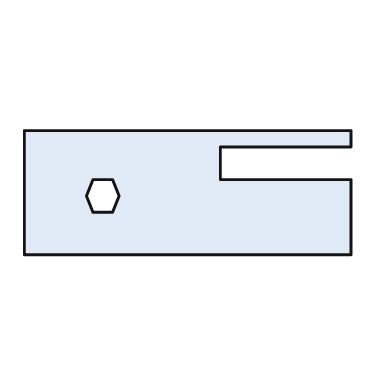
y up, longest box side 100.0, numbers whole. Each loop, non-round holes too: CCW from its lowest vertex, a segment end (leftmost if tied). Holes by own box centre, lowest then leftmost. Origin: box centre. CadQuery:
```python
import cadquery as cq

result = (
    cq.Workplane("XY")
    .moveTo(-50.0, -19.0)
    .lineTo(50.0, -19.0)
    .lineTo(50.0, 4.0)
    .lineTo(10.0, 4.0)
    .lineTo(10.0, 14.0)
    .lineTo(50.0, 14.0)
    .lineTo(50.0, 19.0)
    .lineTo(-50.0, 19.0)
    .close()
    .moveTo(-29.0, -6.0)
    .lineTo(-23.0, -6.0)
    .lineTo(-21.0, -1.0)
    .lineTo(-23.0, 4.0)
    .lineTo(-29.0, 4.0)
    .lineTo(-31.0, -1.0)
    .close()
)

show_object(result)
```